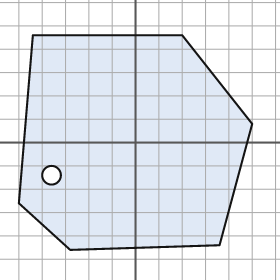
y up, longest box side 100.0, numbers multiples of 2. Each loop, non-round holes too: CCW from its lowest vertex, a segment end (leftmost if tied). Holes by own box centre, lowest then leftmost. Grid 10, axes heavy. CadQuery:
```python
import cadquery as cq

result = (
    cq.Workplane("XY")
    .moveTo(-28.0, -46.0)
    .lineTo(36.0, -44.0)
    .lineTo(50.0, 8.0)
    .lineTo(20.0, 46.0)
    .lineTo(-44.0, 46.0)
    .lineTo(-50.0, -26.0)
    .close()
    .moveTo(-36.0, -14.0)
    .circle(4.0)
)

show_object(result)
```